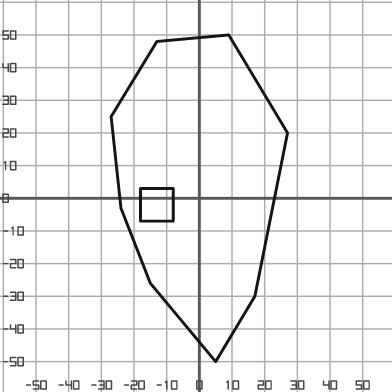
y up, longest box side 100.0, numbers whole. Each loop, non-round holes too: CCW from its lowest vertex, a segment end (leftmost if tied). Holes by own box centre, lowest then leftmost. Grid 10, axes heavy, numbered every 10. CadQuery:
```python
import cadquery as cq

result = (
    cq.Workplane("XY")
    .moveTo(5.0, -50.0)
    .lineTo(17.0, -30.0)
    .lineTo(27.0, 20.0)
    .lineTo(9.0, 50.0)
    .lineTo(-13.0, 48.0)
    .lineTo(-27.0, 25.0)
    .lineTo(-24.0, -3.0)
    .lineTo(-15.0, -26.0)
    .close()
    .moveTo(-18.0, -7.0)
    .lineTo(-8.0, -7.0)
    .lineTo(-8.0, 3.0)
    .lineTo(-18.0, 3.0)
    .close()
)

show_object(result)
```